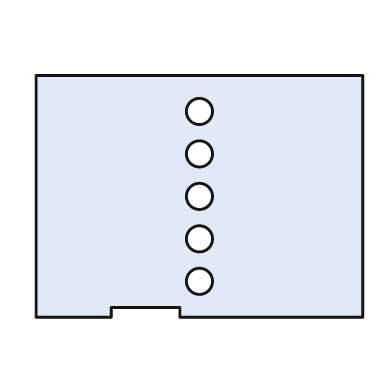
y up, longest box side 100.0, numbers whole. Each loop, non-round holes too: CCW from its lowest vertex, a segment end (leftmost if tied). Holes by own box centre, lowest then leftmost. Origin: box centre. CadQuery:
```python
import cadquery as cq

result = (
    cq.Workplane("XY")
    .moveTo(-50.0, -37.0)
    .lineTo(-27.0, -37.0)
    .lineTo(-27.0, -34.0)
    .lineTo(-6.0, -34.0)
    .lineTo(-6.0, -37.0)
    .lineTo(50.0, -37.0)
    .lineTo(50.0, 37.0)
    .lineTo(-50.0, 37.0)
    .close()
    .moveTo(0.0, -26.0)
    .circle(4.0)
    .moveTo(0.0, -13.0)
    .circle(4.0)
    .moveTo(0.0, 0.0)
    .circle(4.0)
    .moveTo(0.0, 13.0)
    .circle(4.0)
    .moveTo(0.0, 26.0)
    .circle(4.0)
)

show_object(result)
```